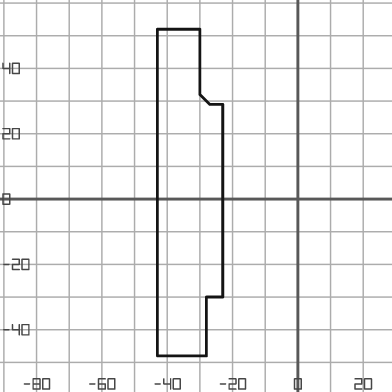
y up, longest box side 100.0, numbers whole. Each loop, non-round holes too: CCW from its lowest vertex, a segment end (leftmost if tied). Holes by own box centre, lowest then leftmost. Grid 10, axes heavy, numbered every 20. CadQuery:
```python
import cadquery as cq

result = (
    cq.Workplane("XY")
    .moveTo(-43.0, -48.0)
    .lineTo(-28.0, -48.0)
    .lineTo(-28.0, -30.0)
    .lineTo(-23.0, -30.0)
    .lineTo(-23.0, 29.0)
    .lineTo(-27.0, 29.0)
    .lineTo(-30.0, 32.0)
    .lineTo(-30.0, 52.0)
    .lineTo(-43.0, 52.0)
    .close()
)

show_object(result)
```